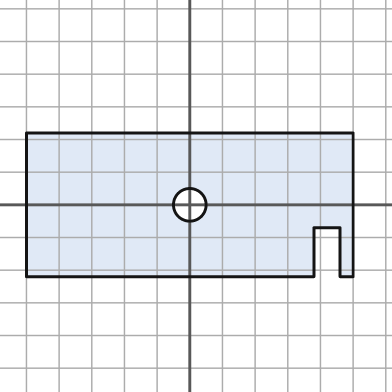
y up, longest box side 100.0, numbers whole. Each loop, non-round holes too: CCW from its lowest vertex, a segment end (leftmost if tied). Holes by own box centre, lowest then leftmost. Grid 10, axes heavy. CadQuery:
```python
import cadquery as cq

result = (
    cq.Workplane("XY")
    .moveTo(-50.0, -22.0)
    .lineTo(38.0, -22.0)
    .lineTo(38.0, -7.0)
    .lineTo(46.0, -7.0)
    .lineTo(46.0, -22.0)
    .lineTo(50.0, -22.0)
    .lineTo(50.0, 22.0)
    .lineTo(-50.0, 22.0)
    .close()
    .moveTo(0.0, 0.0)
    .circle(5.0)
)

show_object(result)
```